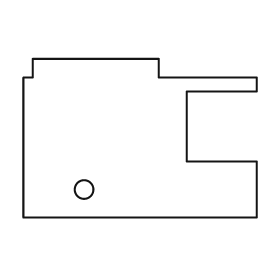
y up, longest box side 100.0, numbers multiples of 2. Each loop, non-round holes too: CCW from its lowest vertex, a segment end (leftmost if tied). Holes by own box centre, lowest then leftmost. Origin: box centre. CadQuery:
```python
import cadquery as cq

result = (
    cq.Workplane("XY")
    .moveTo(-50.0, -34.0)
    .lineTo(50.0, -34.0)
    .lineTo(50.0, -10.0)
    .lineTo(20.0, -10.0)
    .lineTo(20.0, 20.0)
    .lineTo(50.0, 20.0)
    .lineTo(50.0, 26.0)
    .lineTo(8.0, 26.0)
    .lineTo(8.0, 34.0)
    .lineTo(-46.0, 34.0)
    .lineTo(-46.0, 26.0)
    .lineTo(-50.0, 26.0)
    .close()
    .moveTo(-24.0, -22.0)
    .circle(4.0)
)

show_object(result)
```